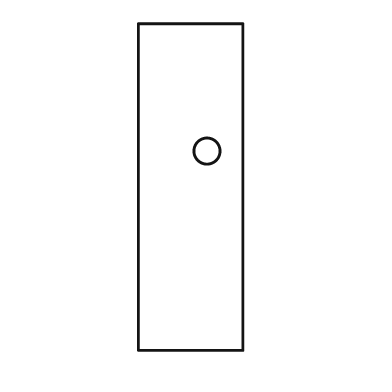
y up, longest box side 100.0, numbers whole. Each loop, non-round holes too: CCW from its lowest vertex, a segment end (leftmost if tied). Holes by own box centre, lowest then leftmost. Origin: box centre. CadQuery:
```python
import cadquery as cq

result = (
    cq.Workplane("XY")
    .moveTo(-16.0, -50.0)
    .lineTo(16.0, -50.0)
    .lineTo(16.0, 50.0)
    .lineTo(-16.0, 50.0)
    .close()
    .moveTo(5.0, 11.0)
    .circle(4.0)
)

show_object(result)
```